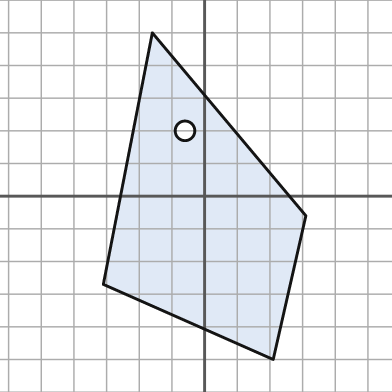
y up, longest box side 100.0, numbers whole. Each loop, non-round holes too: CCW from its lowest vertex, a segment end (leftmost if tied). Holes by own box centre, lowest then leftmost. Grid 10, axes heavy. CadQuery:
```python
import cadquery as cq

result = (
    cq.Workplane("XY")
    .moveTo(21.0, -50.0)
    .lineTo(31.0, -6.0)
    .lineTo(-16.0, 50.0)
    .lineTo(-31.0, -27.0)
    .close()
    .moveTo(-6.0, 20.0)
    .circle(3.0)
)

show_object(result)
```